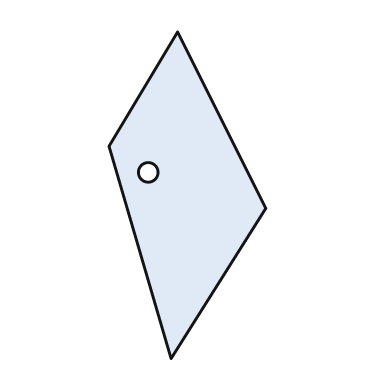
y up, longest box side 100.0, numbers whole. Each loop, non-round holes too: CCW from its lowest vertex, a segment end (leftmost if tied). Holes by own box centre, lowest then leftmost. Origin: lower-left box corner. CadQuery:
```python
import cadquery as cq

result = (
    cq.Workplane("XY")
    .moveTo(19.0, 0.0)
    .lineTo(48.0, 46.0)
    .lineTo(21.0, 100.0)
    .lineTo(0.0, 65.0)
    .close()
    .moveTo(12.0, 57.0)
    .circle(3.0)
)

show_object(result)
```